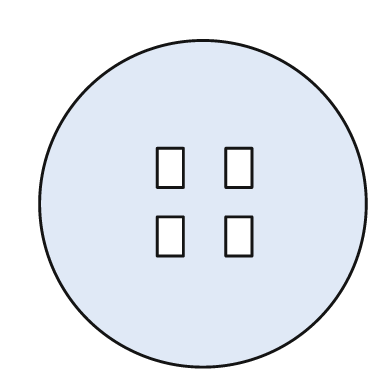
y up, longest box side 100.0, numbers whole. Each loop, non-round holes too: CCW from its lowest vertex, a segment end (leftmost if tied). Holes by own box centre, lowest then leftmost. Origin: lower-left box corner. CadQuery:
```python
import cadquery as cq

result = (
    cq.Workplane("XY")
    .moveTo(50.0, 50.0)
    .circle(50.0)
    .moveTo(36.0, 34.0)
    .lineTo(44.0, 34.0)
    .lineTo(44.0, 46.0)
    .lineTo(36.0, 46.0)
    .close()
    .moveTo(57.0, 34.0)
    .lineTo(65.0, 34.0)
    .lineTo(65.0, 46.0)
    .lineTo(57.0, 46.0)
    .close()
    .moveTo(36.0, 55.0)
    .lineTo(44.0, 55.0)
    .lineTo(44.0, 67.0)
    .lineTo(36.0, 67.0)
    .close()
    .moveTo(57.0, 55.0)
    .lineTo(65.0, 55.0)
    .lineTo(65.0, 67.0)
    .lineTo(57.0, 67.0)
    .close()
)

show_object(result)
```